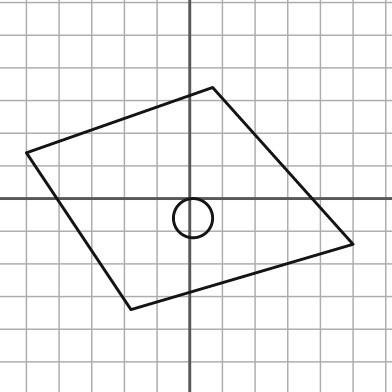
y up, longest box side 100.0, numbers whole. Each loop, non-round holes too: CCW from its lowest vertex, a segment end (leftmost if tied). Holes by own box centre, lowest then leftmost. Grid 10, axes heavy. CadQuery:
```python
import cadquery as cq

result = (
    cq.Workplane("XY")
    .moveTo(-18.0, -34.0)
    .lineTo(50.0, -14.0)
    .lineTo(7.0, 34.0)
    .lineTo(-50.0, 14.0)
    .close()
    .moveTo(1.0, -6.0)
    .circle(6.0)
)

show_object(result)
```